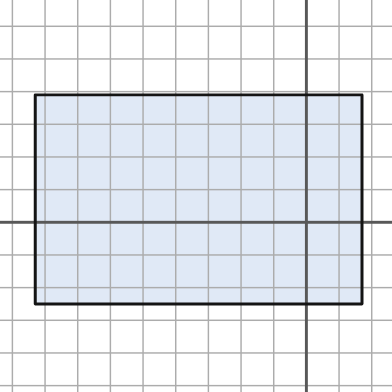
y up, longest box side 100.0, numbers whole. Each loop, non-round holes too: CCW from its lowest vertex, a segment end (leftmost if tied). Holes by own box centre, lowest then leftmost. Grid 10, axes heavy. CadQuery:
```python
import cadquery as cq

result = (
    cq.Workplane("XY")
    .moveTo(-83.0, -25.0)
    .lineTo(17.0, -25.0)
    .lineTo(17.0, 39.0)
    .lineTo(-83.0, 39.0)
    .close()
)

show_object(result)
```